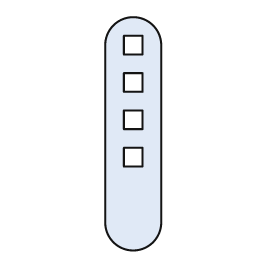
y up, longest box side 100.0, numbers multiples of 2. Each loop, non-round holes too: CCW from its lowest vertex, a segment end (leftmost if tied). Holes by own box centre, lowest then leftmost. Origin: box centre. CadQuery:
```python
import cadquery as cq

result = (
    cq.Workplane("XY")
    .moveTo(-12.0, -38.0)
    .threePointArc((0.0, -50.0), (12.0, -38.0))
    .lineTo(12.0, 38.0)
    .threePointArc((0.0, 50.0), (-12.0, 38.0))
    .close()
    .moveTo(-4.0, -14.0)
    .lineTo(4.0, -14.0)
    .lineTo(4.0, -6.0)
    .lineTo(-4.0, -6.0)
    .close()
    .moveTo(-4.0, 2.0)
    .lineTo(4.0, 2.0)
    .lineTo(4.0, 10.0)
    .lineTo(-4.0, 10.0)
    .close()
    .moveTo(-4.0, 18.0)
    .lineTo(4.0, 18.0)
    .lineTo(4.0, 26.0)
    .lineTo(-4.0, 26.0)
    .close()
    .moveTo(-4.0, 34.0)
    .lineTo(4.0, 34.0)
    .lineTo(4.0, 42.0)
    .lineTo(-4.0, 42.0)
    .close()
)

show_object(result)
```